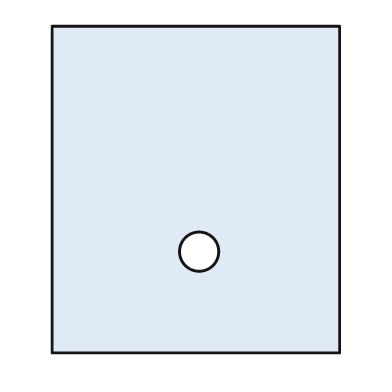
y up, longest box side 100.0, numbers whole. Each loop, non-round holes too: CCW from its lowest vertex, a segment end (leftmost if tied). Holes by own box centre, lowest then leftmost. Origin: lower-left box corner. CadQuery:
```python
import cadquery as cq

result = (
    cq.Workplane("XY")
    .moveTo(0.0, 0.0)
    .lineTo(88.0, 0.0)
    .lineTo(88.0, 100.0)
    .lineTo(0.0, 100.0)
    .close()
    .moveTo(45.0, 31.0)
    .circle(6.0)
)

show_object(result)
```